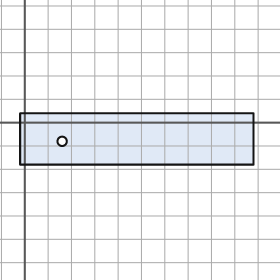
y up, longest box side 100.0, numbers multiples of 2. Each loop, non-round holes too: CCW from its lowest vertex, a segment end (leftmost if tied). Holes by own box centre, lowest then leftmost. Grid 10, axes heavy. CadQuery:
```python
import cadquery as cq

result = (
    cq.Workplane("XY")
    .moveTo(-2.0, -18.0)
    .lineTo(98.0, -18.0)
    .lineTo(98.0, 4.0)
    .lineTo(-2.0, 4.0)
    .close()
    .moveTo(16.0, -8.0)
    .circle(2.0)
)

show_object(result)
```